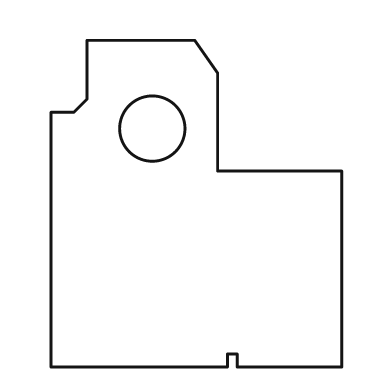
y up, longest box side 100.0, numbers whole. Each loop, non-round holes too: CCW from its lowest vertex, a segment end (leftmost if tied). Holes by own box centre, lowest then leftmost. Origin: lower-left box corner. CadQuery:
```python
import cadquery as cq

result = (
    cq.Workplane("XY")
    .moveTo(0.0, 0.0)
    .lineTo(54.0, 0.0)
    .lineTo(54.0, 4.0)
    .lineTo(57.0, 4.0)
    .lineTo(57.0, 0.0)
    .lineTo(89.0, 0.0)
    .lineTo(89.0, 60.0)
    .lineTo(51.0, 60.0)
    .lineTo(51.0, 90.0)
    .lineTo(44.0, 100.0)
    .lineTo(11.0, 100.0)
    .lineTo(11.0, 82.0)
    .lineTo(7.0, 78.0)
    .lineTo(0.0, 78.0)
    .close()
    .moveTo(31.0, 73.0)
    .circle(10.0)
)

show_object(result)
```